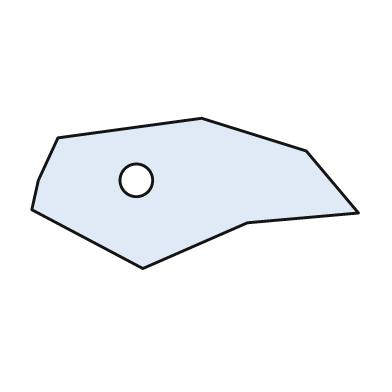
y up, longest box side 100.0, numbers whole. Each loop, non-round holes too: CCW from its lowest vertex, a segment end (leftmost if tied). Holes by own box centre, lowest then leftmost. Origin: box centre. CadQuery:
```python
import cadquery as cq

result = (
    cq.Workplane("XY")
    .moveTo(-16.0, -23.0)
    .lineTo(16.0, -9.0)
    .lineTo(50.0, -6.0)
    .lineTo(34.0, 13.0)
    .lineTo(2.0, 23.0)
    .lineTo(-42.0, 17.0)
    .lineTo(-48.0, 4.0)
    .lineTo(-50.0, -5.0)
    .close()
    .moveTo(-18.0, 4.0)
    .circle(5.0)
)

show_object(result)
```